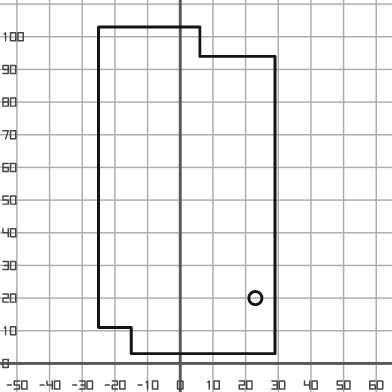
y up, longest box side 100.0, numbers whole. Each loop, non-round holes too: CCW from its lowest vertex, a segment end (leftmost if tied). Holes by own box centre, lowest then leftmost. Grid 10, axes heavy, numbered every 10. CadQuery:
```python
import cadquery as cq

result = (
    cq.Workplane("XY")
    .moveTo(-15.0, 3.0)
    .lineTo(29.0, 3.0)
    .lineTo(29.0, 94.0)
    .lineTo(6.0, 94.0)
    .lineTo(6.0, 103.0)
    .lineTo(-25.0, 103.0)
    .lineTo(-25.0, 11.0)
    .lineTo(-15.0, 11.0)
    .close()
    .moveTo(23.0, 20.0)
    .circle(2.0)
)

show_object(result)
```